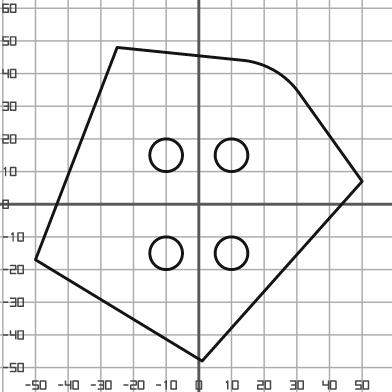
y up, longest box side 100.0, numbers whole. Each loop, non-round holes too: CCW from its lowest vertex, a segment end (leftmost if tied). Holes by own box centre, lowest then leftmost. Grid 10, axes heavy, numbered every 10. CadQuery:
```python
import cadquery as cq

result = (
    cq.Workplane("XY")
    .moveTo(1.0, -48.0)
    .lineTo(50.0, 7.0)
    .lineTo(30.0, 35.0)
    .threePointArc((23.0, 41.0), (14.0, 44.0))
    .lineTo(-25.0, 48.0)
    .lineTo(-50.0, -17.0)
    .close()
    .moveTo(-10.0, -15.0)
    .circle(5.0)
    .moveTo(10.0, -15.0)
    .circle(5.0)
    .moveTo(-10.0, 15.0)
    .circle(5.0)
    .moveTo(10.0, 15.0)
    .circle(5.0)
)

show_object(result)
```